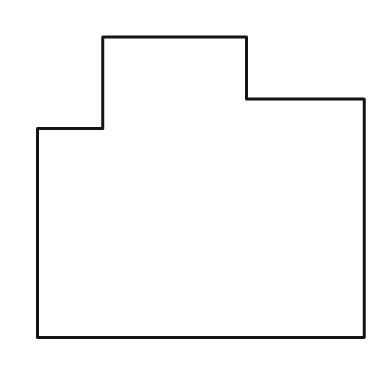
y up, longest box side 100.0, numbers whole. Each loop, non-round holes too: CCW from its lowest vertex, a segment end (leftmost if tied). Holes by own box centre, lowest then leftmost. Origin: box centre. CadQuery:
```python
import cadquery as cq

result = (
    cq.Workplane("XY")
    .moveTo(-50.0, -46.0)
    .lineTo(50.0, -46.0)
    .lineTo(50.0, 27.0)
    .lineTo(14.0, 27.0)
    .lineTo(14.0, 46.0)
    .lineTo(-30.0, 46.0)
    .lineTo(-30.0, 18.0)
    .lineTo(-50.0, 18.0)
    .close()
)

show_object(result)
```